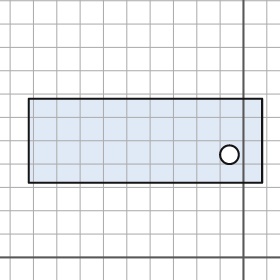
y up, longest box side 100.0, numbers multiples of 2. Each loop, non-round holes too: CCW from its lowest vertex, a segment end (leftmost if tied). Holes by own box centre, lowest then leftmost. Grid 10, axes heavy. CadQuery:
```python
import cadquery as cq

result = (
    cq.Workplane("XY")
    .moveTo(-92.0, 32.0)
    .lineTo(8.0, 32.0)
    .lineTo(8.0, 68.0)
    .lineTo(-92.0, 68.0)
    .close()
    .moveTo(-6.0, 44.0)
    .circle(4.0)
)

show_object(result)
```